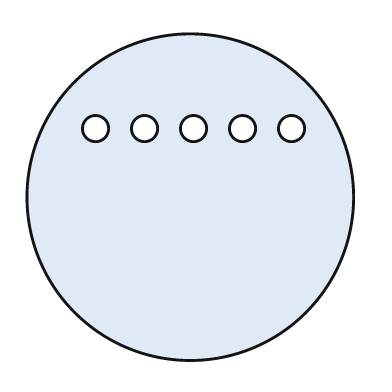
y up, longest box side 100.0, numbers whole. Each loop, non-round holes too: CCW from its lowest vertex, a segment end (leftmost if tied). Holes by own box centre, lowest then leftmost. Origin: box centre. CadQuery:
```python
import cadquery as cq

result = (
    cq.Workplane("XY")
    .moveTo(0.0, 0.0)
    .circle(50.0)
    .moveTo(-29.0, 21.0)
    .circle(4.0)
    .moveTo(-14.0, 21.0)
    .circle(4.0)
    .moveTo(1.0, 21.0)
    .circle(4.0)
    .moveTo(16.0, 21.0)
    .circle(4.0)
    .moveTo(31.0, 21.0)
    .circle(4.0)
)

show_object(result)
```